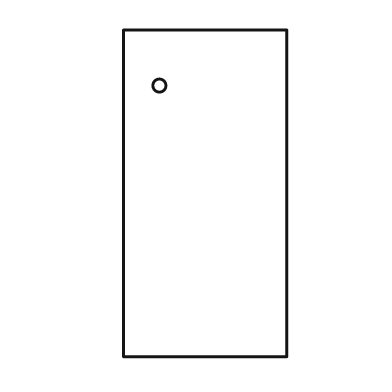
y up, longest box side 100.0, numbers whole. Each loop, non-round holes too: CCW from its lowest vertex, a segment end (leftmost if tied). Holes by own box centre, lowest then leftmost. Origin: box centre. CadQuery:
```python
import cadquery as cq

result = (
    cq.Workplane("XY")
    .moveTo(-25.0, -50.0)
    .lineTo(25.0, -50.0)
    .lineTo(25.0, 50.0)
    .lineTo(-25.0, 50.0)
    .close()
    .moveTo(-14.0, 33.0)
    .circle(2.0)
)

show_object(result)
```